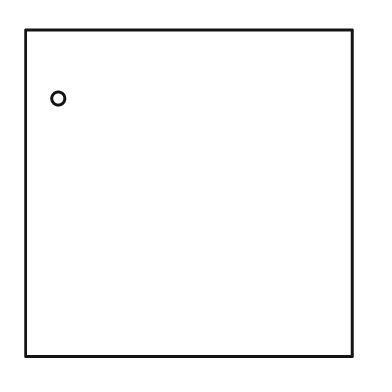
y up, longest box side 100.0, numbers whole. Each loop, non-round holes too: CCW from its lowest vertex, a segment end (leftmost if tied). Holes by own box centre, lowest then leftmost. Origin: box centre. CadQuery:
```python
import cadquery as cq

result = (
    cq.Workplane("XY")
    .moveTo(-50.0, -50.0)
    .lineTo(50.0, -50.0)
    .lineTo(50.0, 50.0)
    .lineTo(-50.0, 50.0)
    .close()
    .moveTo(-40.0, 29.0)
    .circle(2.0)
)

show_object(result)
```